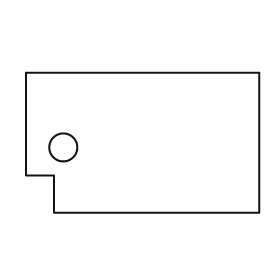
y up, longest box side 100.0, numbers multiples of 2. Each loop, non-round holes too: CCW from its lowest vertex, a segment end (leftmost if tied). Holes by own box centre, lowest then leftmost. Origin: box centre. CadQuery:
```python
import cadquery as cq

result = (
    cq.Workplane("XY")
    .moveTo(-38.0, -30.0)
    .lineTo(50.0, -30.0)
    .lineTo(50.0, 30.0)
    .lineTo(-50.0, 30.0)
    .lineTo(-50.0, -14.0)
    .lineTo(-38.0, -14.0)
    .close()
    .moveTo(-34.0, -2.0)
    .circle(6.0)
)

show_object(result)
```